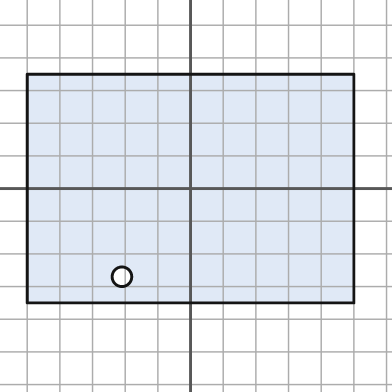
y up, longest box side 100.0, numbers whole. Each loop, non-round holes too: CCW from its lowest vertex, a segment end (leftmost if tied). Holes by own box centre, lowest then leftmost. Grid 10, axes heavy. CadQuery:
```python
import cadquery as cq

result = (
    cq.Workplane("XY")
    .moveTo(-50.0, -35.0)
    .lineTo(50.0, -35.0)
    .lineTo(50.0, 35.0)
    .lineTo(-50.0, 35.0)
    .close()
    .moveTo(-21.0, -27.0)
    .circle(3.0)
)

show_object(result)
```